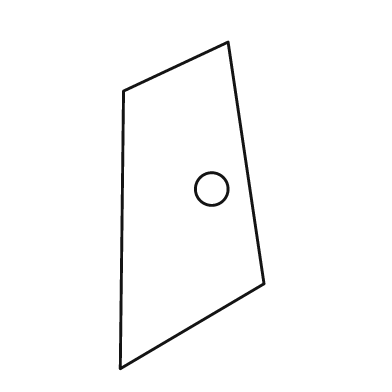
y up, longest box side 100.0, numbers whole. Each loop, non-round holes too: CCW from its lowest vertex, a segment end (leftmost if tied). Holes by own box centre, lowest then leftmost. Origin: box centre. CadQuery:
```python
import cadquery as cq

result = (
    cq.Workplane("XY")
    .moveTo(-22.0, -50.0)
    .lineTo(22.0, -24.0)
    .lineTo(11.0, 50.0)
    .lineTo(-21.0, 35.0)
    .close()
    .moveTo(6.0, 5.0)
    .circle(5.0)
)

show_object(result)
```